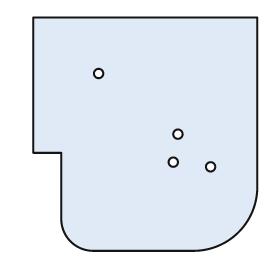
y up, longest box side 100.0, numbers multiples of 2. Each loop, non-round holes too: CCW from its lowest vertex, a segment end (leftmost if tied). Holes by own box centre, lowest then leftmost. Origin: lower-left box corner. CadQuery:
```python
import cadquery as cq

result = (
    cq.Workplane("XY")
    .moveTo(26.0, 0.0)
    .lineTo(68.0, 0.0)
    .threePointArc((88.0, 8.0), (96.0, 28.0))
    .lineTo(96.0, 100.0)
    .lineTo(0.0, 100.0)
    .lineTo(0.0, 42.0)
    .lineTo(12.0, 42.0)
    .lineTo(12.0, 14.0)
    .threePointArc((16.0, 4.0), (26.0, 0.0))
    .close()
    .moveTo(76.0, 36.0)
    .circle(2.0)
    .moveTo(60.0, 38.0)
    .circle(2.0)
    .moveTo(62.0, 50.0)
    .circle(2.0)
    .moveTo(28.0, 76.0)
    .circle(2.0)
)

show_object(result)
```